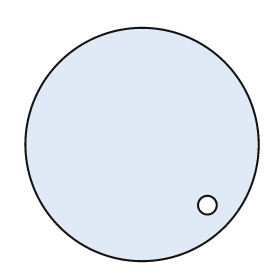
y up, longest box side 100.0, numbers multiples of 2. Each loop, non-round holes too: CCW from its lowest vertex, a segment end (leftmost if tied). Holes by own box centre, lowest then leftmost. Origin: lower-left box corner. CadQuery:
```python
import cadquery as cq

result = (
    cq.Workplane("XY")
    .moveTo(50.0, 50.0)
    .circle(50.0)
    .moveTo(78.0, 24.0)
    .circle(4.0)
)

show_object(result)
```